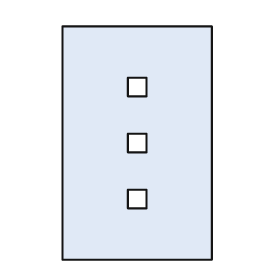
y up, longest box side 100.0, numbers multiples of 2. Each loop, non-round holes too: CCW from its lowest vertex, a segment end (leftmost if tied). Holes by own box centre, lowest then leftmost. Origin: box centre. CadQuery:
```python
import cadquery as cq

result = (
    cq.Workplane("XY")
    .moveTo(-32.0, -50.0)
    .lineTo(32.0, -50.0)
    .lineTo(32.0, 50.0)
    .lineTo(-32.0, 50.0)
    .close()
    .moveTo(-4.0, -28.0)
    .lineTo(4.0, -28.0)
    .lineTo(4.0, -20.0)
    .lineTo(-4.0, -20.0)
    .close()
    .moveTo(-4.0, -4.0)
    .lineTo(4.0, -4.0)
    .lineTo(4.0, 4.0)
    .lineTo(-4.0, 4.0)
    .close()
    .moveTo(-4.0, 20.0)
    .lineTo(4.0, 20.0)
    .lineTo(4.0, 28.0)
    .lineTo(-4.0, 28.0)
    .close()
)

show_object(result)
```